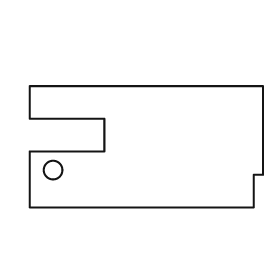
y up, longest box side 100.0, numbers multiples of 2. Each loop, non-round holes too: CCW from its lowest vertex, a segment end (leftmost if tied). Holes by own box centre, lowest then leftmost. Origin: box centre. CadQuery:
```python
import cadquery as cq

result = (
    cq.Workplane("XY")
    .moveTo(-50.0, -26.0)
    .lineTo(46.0, -26.0)
    .lineTo(46.0, -12.0)
    .lineTo(50.0, -12.0)
    .lineTo(50.0, 26.0)
    .lineTo(-50.0, 26.0)
    .lineTo(-50.0, 12.0)
    .lineTo(-18.0, 12.0)
    .lineTo(-18.0, -2.0)
    .lineTo(-50.0, -2.0)
    .close()
    .moveTo(-40.0, -10.0)
    .circle(4.0)
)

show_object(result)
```